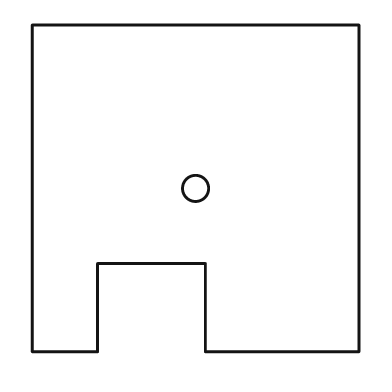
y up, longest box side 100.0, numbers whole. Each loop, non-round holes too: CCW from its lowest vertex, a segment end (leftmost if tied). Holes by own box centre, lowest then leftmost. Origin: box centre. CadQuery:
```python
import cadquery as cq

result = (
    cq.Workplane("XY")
    .moveTo(-50.0, -50.0)
    .lineTo(-30.0, -50.0)
    .lineTo(-30.0, -23.0)
    .lineTo(3.0, -23.0)
    .lineTo(3.0, -50.0)
    .lineTo(50.0, -50.0)
    .lineTo(50.0, 50.0)
    .lineTo(-50.0, 50.0)
    .close()
    .moveTo(0.0, 0.0)
    .circle(4.0)
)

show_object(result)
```